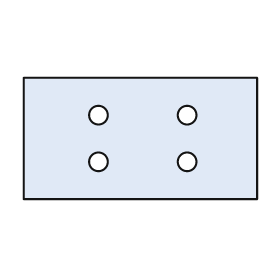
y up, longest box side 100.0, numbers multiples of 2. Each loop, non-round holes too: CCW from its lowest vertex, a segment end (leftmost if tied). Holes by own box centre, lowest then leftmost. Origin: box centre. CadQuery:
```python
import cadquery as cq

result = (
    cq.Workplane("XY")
    .moveTo(-50.0, -26.0)
    .lineTo(50.0, -26.0)
    .lineTo(50.0, 26.0)
    .lineTo(-50.0, 26.0)
    .close()
    .moveTo(-18.0, -10.0)
    .circle(4.0)
    .moveTo(20.0, -10.0)
    .circle(4.0)
    .moveTo(-18.0, 10.0)
    .circle(4.0)
    .moveTo(20.0, 10.0)
    .circle(4.0)
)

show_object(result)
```